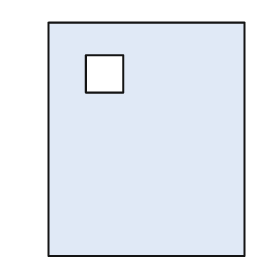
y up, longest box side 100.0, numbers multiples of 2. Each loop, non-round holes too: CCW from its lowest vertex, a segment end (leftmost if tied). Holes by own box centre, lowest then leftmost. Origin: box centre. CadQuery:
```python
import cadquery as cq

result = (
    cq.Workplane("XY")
    .moveTo(-42.0, -50.0)
    .lineTo(42.0, -50.0)
    .lineTo(42.0, 50.0)
    .lineTo(-42.0, 50.0)
    .close()
    .moveTo(-26.0, 20.0)
    .lineTo(-10.0, 20.0)
    .lineTo(-10.0, 36.0)
    .lineTo(-26.0, 36.0)
    .close()
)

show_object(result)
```